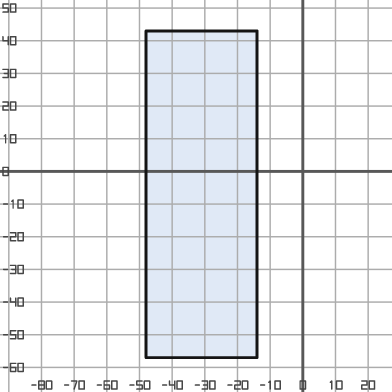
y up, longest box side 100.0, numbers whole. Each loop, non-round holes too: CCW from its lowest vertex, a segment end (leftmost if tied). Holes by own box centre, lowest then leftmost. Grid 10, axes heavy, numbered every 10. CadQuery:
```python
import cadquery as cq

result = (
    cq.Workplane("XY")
    .moveTo(-48.0, -57.0)
    .lineTo(-14.0, -57.0)
    .lineTo(-14.0, 43.0)
    .lineTo(-48.0, 43.0)
    .close()
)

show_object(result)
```